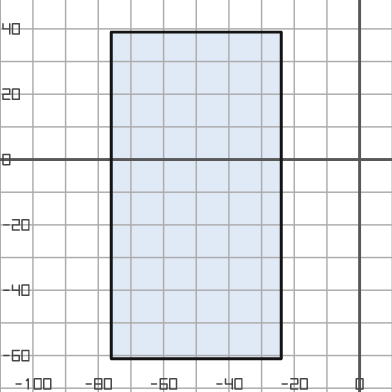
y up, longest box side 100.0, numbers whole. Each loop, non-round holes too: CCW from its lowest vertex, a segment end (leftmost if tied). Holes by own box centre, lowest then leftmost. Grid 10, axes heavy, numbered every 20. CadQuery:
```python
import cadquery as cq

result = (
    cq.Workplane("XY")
    .moveTo(-76.0, -61.0)
    .lineTo(-24.0, -61.0)
    .lineTo(-24.0, 39.0)
    .lineTo(-76.0, 39.0)
    .close()
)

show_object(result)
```